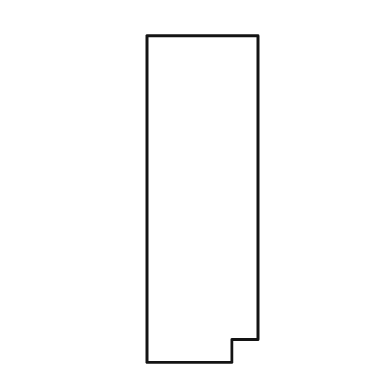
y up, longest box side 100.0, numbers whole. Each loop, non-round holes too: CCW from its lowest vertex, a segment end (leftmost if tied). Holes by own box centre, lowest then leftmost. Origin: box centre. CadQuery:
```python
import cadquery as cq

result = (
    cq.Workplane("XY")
    .moveTo(-17.0, -50.0)
    .lineTo(9.0, -50.0)
    .lineTo(9.0, -43.0)
    .lineTo(17.0, -43.0)
    .lineTo(17.0, 50.0)
    .lineTo(-17.0, 50.0)
    .close()
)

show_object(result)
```